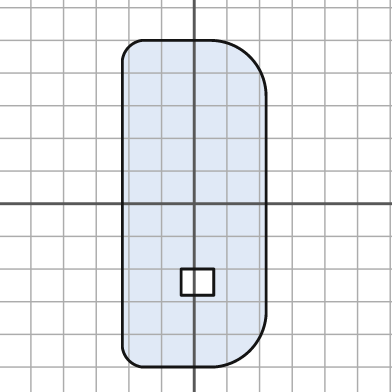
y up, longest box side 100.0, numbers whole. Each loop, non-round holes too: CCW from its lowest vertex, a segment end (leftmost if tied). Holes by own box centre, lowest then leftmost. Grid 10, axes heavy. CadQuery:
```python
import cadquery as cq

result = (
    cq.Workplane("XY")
    .moveTo(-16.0, -50.0)
    .lineTo(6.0, -50.0)
    .threePointArc((17.0, -45.0), (22.0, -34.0))
    .lineTo(22.0, 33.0)
    .threePointArc((17.0, 45.0), (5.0, 50.0))
    .lineTo(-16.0, 50.0)
    .threePointArc((-20.0, 48.0), (-22.0, 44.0))
    .lineTo(-22.0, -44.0)
    .threePointArc((-20.0, -48.0), (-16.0, -50.0))
    .close()
    .moveTo(-4.0, -28.0)
    .lineTo(6.0, -28.0)
    .lineTo(6.0, -20.0)
    .lineTo(-4.0, -20.0)
    .close()
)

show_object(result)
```